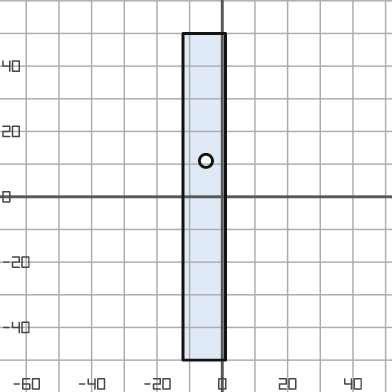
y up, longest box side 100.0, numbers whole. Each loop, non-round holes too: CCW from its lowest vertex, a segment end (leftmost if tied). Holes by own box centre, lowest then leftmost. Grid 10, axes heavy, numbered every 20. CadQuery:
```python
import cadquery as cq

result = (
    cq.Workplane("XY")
    .moveTo(-12.0, -50.0)
    .lineTo(1.0, -50.0)
    .lineTo(1.0, 50.0)
    .lineTo(-12.0, 50.0)
    .close()
    .moveTo(-5.0, 11.0)
    .circle(2.0)
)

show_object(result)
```